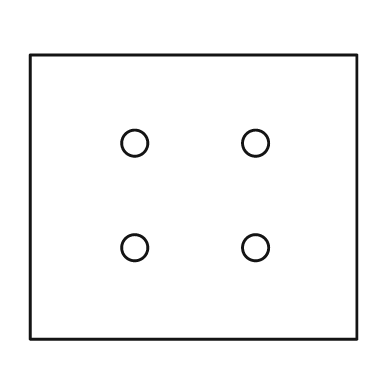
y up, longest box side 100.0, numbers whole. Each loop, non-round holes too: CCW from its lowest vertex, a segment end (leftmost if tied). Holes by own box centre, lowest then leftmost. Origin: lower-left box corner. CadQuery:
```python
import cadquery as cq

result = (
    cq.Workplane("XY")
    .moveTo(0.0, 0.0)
    .lineTo(100.0, 0.0)
    .lineTo(100.0, 87.0)
    .lineTo(0.0, 87.0)
    .close()
    .moveTo(32.0, 28.0)
    .circle(4.0)
    .moveTo(69.0, 28.0)
    .circle(4.0)
    .moveTo(32.0, 60.0)
    .circle(4.0)
    .moveTo(69.0, 60.0)
    .circle(4.0)
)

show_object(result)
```